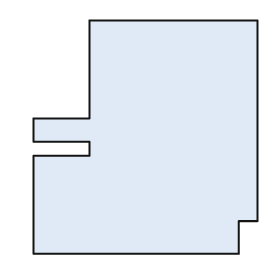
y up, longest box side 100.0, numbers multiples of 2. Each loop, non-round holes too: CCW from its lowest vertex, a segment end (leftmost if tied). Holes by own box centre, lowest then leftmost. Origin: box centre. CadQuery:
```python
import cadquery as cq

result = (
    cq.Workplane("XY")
    .moveTo(-48.0, -50.0)
    .lineTo(40.0, -50.0)
    .lineTo(40.0, -36.0)
    .lineTo(48.0, -36.0)
    .lineTo(48.0, 50.0)
    .lineTo(-24.0, 50.0)
    .lineTo(-24.0, 8.0)
    .lineTo(-48.0, 8.0)
    .lineTo(-48.0, -2.0)
    .lineTo(-24.0, -2.0)
    .lineTo(-24.0, -8.0)
    .lineTo(-48.0, -8.0)
    .close()
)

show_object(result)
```